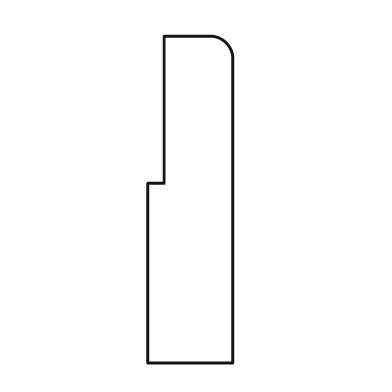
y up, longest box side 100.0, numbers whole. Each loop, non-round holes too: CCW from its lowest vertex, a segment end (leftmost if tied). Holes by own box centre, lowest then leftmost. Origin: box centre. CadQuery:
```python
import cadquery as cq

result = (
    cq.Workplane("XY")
    .moveTo(-13.0, -50.0)
    .lineTo(13.0, -50.0)
    .lineTo(13.0, 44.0)
    .threePointArc((11.0, 48.0), (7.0, 50.0))
    .lineTo(-8.0, 50.0)
    .lineTo(-8.0, 5.0)
    .lineTo(-13.0, 5.0)
    .close()
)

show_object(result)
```